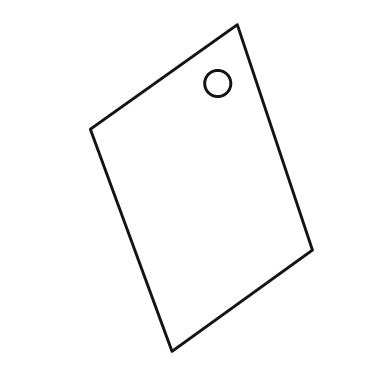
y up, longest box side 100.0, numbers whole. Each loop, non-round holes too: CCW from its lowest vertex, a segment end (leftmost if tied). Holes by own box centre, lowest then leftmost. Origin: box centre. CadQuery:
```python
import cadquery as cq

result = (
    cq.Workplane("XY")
    .moveTo(-9.0, -50.0)
    .lineTo(34.0, -19.0)
    .lineTo(11.0, 50.0)
    .lineTo(-34.0, 18.0)
    .close()
    .moveTo(5.0, 32.0)
    .circle(4.0)
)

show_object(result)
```